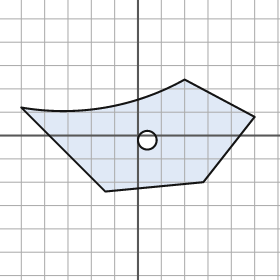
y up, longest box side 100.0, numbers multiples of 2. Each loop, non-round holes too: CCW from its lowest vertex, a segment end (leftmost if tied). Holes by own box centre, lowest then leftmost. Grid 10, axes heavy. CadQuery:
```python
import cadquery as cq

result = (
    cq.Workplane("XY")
    .moveTo(-14.0, -24.0)
    .lineTo(28.0, -20.0)
    .lineTo(50.0, 8.0)
    .lineTo(20.0, 24.0)
    .threePointArc((-14.0, 12.0), (-50.0, 12.0))
    .close()
    .moveTo(4.0, -2.0)
    .circle(4.0)
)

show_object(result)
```